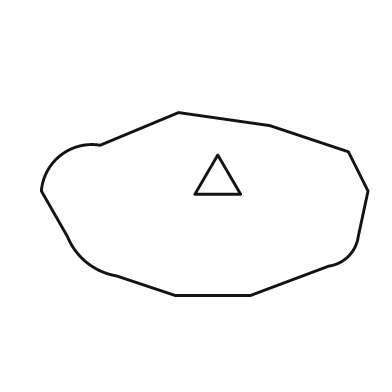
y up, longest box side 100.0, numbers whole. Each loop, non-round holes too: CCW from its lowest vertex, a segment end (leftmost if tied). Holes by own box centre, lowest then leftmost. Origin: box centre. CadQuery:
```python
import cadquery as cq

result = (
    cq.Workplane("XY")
    .moveTo(-9.0, -28.0)
    .lineTo(14.0, -28.0)
    .lineTo(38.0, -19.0)
    .threePointArc((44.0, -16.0), (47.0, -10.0))
    .lineTo(50.0, 4.0)
    .lineTo(44.0, 16.0)
    .lineTo(20.0, 24.0)
    .lineTo(-8.0, 28.0)
    .lineTo(-32.0, 18.0)
    .threePointArc((-44.0, 15.0), (-50.0, 4.0))
    .lineTo(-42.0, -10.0)
    .threePointArc((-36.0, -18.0), (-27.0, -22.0))
    .close()
    .moveTo(-3.0, 3.0)
    .lineTo(11.0, 3.0)
    .lineTo(4.0, 15.0)
    .close()
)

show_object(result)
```